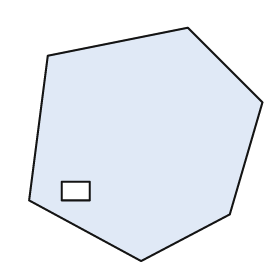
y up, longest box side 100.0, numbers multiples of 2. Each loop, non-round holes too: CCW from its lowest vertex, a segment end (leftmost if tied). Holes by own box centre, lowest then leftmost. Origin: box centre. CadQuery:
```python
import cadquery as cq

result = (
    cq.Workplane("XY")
    .moveTo(-2.0, -50.0)
    .lineTo(36.0, -30.0)
    .lineTo(50.0, 18.0)
    .lineTo(18.0, 50.0)
    .lineTo(-42.0, 38.0)
    .lineTo(-50.0, -24.0)
    .close()
    .moveTo(-36.0, -24.0)
    .lineTo(-24.0, -24.0)
    .lineTo(-24.0, -16.0)
    .lineTo(-36.0, -16.0)
    .close()
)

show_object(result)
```